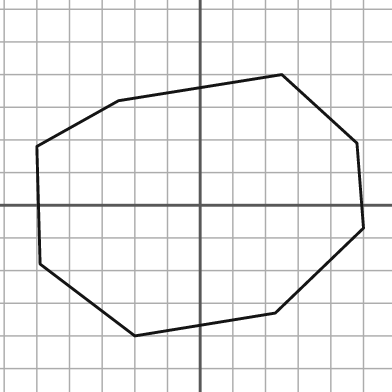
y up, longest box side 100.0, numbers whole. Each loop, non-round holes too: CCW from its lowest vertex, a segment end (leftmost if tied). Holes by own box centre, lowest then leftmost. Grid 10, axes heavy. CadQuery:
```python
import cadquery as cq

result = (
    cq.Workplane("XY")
    .moveTo(-20.0, -40.0)
    .lineTo(23.0, -33.0)
    .lineTo(50.0, -7.0)
    .lineTo(48.0, 19.0)
    .lineTo(25.0, 40.0)
    .lineTo(-25.0, 32.0)
    .lineTo(-50.0, 18.0)
    .lineTo(-49.0, -18.0)
    .close()
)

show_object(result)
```